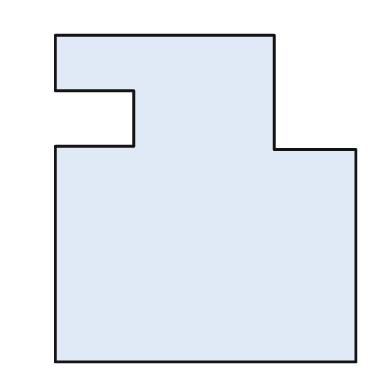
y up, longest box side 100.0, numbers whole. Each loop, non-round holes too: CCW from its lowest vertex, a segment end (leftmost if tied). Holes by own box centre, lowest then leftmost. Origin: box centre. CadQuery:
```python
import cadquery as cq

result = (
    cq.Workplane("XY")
    .moveTo(-46.0, -50.0)
    .lineTo(46.0, -50.0)
    .lineTo(46.0, 15.0)
    .lineTo(21.0, 15.0)
    .lineTo(21.0, 50.0)
    .lineTo(-46.0, 50.0)
    .lineTo(-46.0, 33.0)
    .lineTo(-22.0, 33.0)
    .lineTo(-22.0, 16.0)
    .lineTo(-46.0, 16.0)
    .close()
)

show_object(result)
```